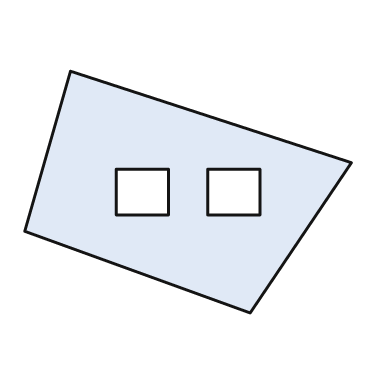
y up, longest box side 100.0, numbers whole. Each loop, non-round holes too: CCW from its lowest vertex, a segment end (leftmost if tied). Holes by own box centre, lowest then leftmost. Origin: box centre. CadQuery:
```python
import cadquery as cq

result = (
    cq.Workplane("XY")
    .moveTo(19.0, -37.0)
    .lineTo(50.0, 9.0)
    .lineTo(-36.0, 37.0)
    .lineTo(-50.0, -12.0)
    .close()
    .moveTo(-22.0, -7.0)
    .lineTo(-6.0, -7.0)
    .lineTo(-6.0, 7.0)
    .lineTo(-22.0, 7.0)
    .close()
    .moveTo(6.0, -7.0)
    .lineTo(22.0, -7.0)
    .lineTo(22.0, 7.0)
    .lineTo(6.0, 7.0)
    .close()
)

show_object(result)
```